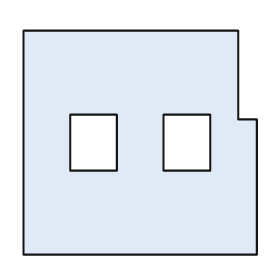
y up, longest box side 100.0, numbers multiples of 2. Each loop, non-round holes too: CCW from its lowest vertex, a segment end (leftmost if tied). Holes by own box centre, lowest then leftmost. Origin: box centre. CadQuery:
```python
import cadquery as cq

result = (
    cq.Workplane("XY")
    .moveTo(-50.0, -48.0)
    .lineTo(50.0, -48.0)
    .lineTo(50.0, 10.0)
    .lineTo(42.0, 10.0)
    .lineTo(42.0, 48.0)
    .lineTo(-50.0, 48.0)
    .close()
    .moveTo(-30.0, -12.0)
    .lineTo(-10.0, -12.0)
    .lineTo(-10.0, 12.0)
    .lineTo(-30.0, 12.0)
    .close()
    .moveTo(10.0, -12.0)
    .lineTo(30.0, -12.0)
    .lineTo(30.0, 12.0)
    .lineTo(10.0, 12.0)
    .close()
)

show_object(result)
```